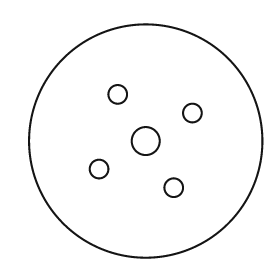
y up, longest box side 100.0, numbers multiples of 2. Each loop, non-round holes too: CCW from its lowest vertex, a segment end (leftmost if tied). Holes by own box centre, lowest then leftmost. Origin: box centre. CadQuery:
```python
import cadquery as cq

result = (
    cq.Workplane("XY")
    .moveTo(0.0, 0.0)
    .circle(50.0)
    .moveTo(12.0, -20.0)
    .circle(4.0)
    .moveTo(-20.0, -12.0)
    .circle(4.0)
    .moveTo(0.0, 0.0)
    .circle(6.0)
    .moveTo(20.0, 12.0)
    .circle(4.0)
    .moveTo(-12.0, 20.0)
    .circle(4.0)
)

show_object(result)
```